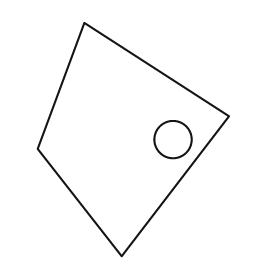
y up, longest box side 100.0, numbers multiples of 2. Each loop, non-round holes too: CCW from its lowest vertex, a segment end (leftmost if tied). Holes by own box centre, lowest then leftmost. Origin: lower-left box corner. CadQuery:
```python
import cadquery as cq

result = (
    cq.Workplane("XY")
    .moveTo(36.0, 0.0)
    .lineTo(82.0, 60.0)
    .lineTo(20.0, 100.0)
    .lineTo(0.0, 46.0)
    .close()
    .moveTo(58.0, 50.0)
    .circle(8.0)
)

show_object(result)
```